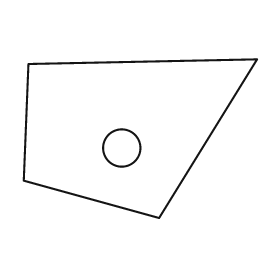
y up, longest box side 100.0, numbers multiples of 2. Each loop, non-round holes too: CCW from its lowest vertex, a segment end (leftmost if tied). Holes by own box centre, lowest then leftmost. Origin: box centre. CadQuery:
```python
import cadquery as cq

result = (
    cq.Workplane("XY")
    .moveTo(8.0, -34.0)
    .lineTo(50.0, 34.0)
    .lineTo(-48.0, 32.0)
    .lineTo(-50.0, -18.0)
    .close()
    .moveTo(-8.0, -4.0)
    .circle(8.0)
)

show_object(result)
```